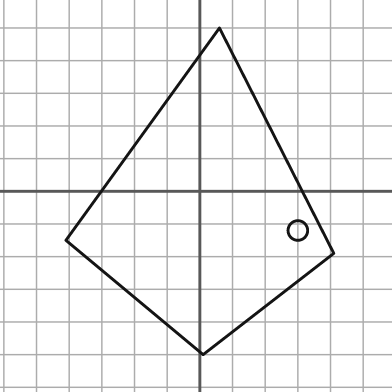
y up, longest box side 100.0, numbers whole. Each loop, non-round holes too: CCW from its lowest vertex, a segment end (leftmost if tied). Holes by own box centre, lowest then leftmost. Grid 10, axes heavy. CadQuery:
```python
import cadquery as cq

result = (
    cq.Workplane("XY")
    .moveTo(1.0, -50.0)
    .lineTo(41.0, -19.0)
    .lineTo(6.0, 50.0)
    .lineTo(-41.0, -15.0)
    .close()
    .moveTo(30.0, -12.0)
    .circle(3.0)
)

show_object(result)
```